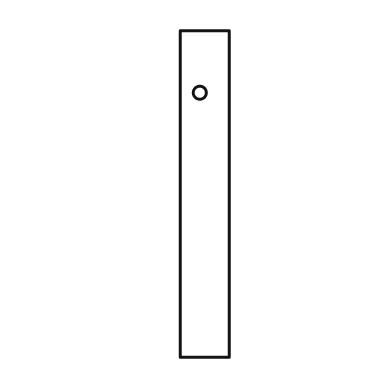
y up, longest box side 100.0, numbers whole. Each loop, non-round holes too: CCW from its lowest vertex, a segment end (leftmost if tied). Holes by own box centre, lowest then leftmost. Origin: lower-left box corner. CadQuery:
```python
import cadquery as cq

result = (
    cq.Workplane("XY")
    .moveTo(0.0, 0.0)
    .lineTo(15.0, 0.0)
    .lineTo(15.0, 100.0)
    .lineTo(0.0, 100.0)
    .close()
    .moveTo(6.0, 81.0)
    .circle(2.0)
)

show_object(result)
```